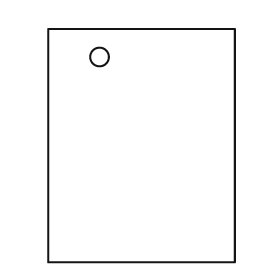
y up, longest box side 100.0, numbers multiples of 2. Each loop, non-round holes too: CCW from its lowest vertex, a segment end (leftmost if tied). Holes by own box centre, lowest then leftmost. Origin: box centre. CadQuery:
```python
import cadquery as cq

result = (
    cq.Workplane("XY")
    .moveTo(-40.0, -50.0)
    .lineTo(40.0, -50.0)
    .lineTo(40.0, 50.0)
    .lineTo(-40.0, 50.0)
    .close()
    .moveTo(-18.0, 38.0)
    .circle(4.0)
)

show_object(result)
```